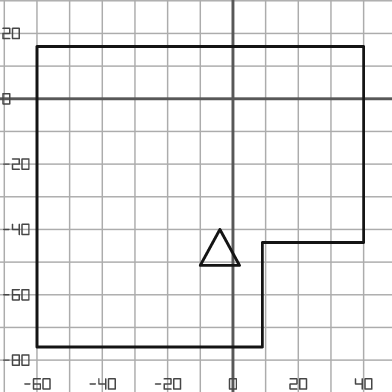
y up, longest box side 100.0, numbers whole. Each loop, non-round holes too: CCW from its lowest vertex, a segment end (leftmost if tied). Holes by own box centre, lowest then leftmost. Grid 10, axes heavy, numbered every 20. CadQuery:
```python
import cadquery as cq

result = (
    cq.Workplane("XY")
    .moveTo(-60.0, -76.0)
    .lineTo(9.0, -76.0)
    .lineTo(9.0, -44.0)
    .lineTo(40.0, -44.0)
    .lineTo(40.0, 16.0)
    .lineTo(-60.0, 16.0)
    .close()
    .moveTo(-10.0, -51.0)
    .lineTo(2.0, -51.0)
    .lineTo(-4.0, -40.0)
    .close()
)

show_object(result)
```